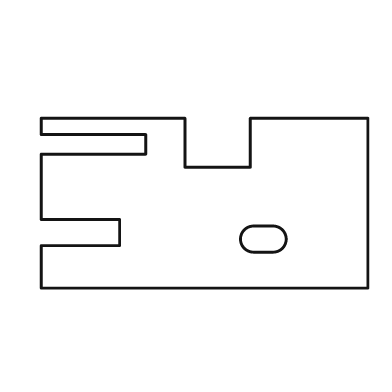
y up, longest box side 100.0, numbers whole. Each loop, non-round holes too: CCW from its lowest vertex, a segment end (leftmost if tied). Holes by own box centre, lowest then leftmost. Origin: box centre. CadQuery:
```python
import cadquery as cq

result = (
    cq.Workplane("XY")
    .moveTo(-50.0, -26.0)
    .lineTo(50.0, -26.0)
    .lineTo(50.0, 26.0)
    .lineTo(14.0, 26.0)
    .lineTo(14.0, 11.0)
    .lineTo(-6.0, 11.0)
    .lineTo(-6.0, 26.0)
    .lineTo(-50.0, 26.0)
    .lineTo(-50.0, 21.0)
    .lineTo(-18.0, 21.0)
    .lineTo(-18.0, 15.0)
    .lineTo(-50.0, 15.0)
    .lineTo(-50.0, -5.0)
    .lineTo(-26.0, -5.0)
    .lineTo(-26.0, -13.0)
    .lineTo(-50.0, -13.0)
    .close()
    .moveTo(15.0, -15.0)
    .lineTo(21.0, -15.0)
    .threePointArc((25.0, -11.0), (21.0, -7.0))
    .lineTo(15.0, -7.0)
    .threePointArc((11.0, -11.0), (15.0, -15.0))
    .close()
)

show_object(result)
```